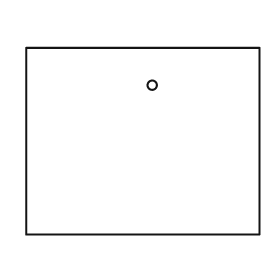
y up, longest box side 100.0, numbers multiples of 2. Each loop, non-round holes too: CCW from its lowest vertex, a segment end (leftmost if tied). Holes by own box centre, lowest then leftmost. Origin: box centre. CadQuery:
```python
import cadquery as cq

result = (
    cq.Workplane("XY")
    .moveTo(-50.0, -40.0)
    .lineTo(50.0, -40.0)
    .lineTo(50.0, 40.0)
    .lineTo(-50.0, 40.0)
    .close()
    .moveTo(4.0, 24.0)
    .circle(2.0)
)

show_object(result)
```